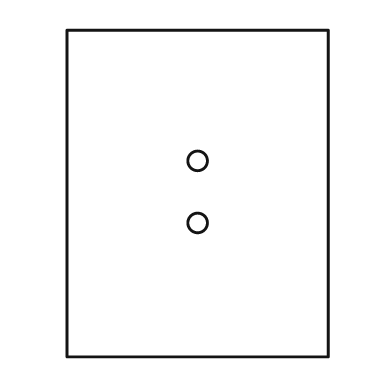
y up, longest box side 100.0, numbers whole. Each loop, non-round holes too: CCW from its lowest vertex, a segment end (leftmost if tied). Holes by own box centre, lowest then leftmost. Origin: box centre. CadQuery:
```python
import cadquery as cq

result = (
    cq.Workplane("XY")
    .moveTo(-40.0, -50.0)
    .lineTo(40.0, -50.0)
    .lineTo(40.0, 50.0)
    .lineTo(-40.0, 50.0)
    .close()
    .moveTo(0.0, -9.0)
    .circle(3.0)
    .moveTo(0.0, 10.0)
    .circle(3.0)
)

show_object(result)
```